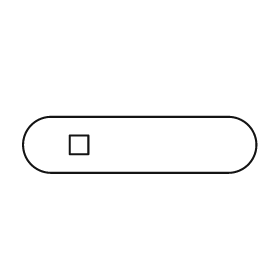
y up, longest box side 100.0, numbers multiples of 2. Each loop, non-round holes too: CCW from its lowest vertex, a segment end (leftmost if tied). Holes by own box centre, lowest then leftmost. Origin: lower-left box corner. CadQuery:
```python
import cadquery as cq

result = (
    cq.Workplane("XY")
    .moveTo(12.0, 0.0)
    .lineTo(88.0, 0.0)
    .threePointArc((100.0, 12.0), (88.0, 24.0))
    .lineTo(12.0, 24.0)
    .threePointArc((0.0, 12.0), (12.0, 0.0))
    .close()
    .moveTo(20.0, 8.0)
    .lineTo(28.0, 8.0)
    .lineTo(28.0, 16.0)
    .lineTo(20.0, 16.0)
    .close()
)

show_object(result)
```